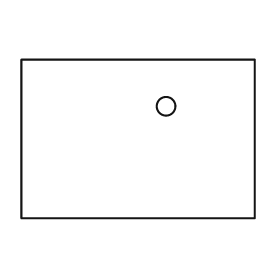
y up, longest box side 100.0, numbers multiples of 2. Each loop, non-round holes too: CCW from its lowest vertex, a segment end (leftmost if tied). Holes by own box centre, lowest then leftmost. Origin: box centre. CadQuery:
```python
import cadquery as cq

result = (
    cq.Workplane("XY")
    .moveTo(-50.0, -34.0)
    .lineTo(50.0, -34.0)
    .lineTo(50.0, 34.0)
    .lineTo(-50.0, 34.0)
    .close()
    .moveTo(12.0, 14.0)
    .circle(4.0)
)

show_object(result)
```